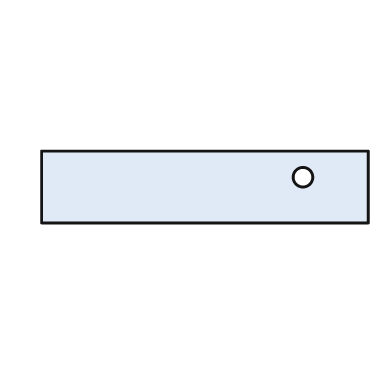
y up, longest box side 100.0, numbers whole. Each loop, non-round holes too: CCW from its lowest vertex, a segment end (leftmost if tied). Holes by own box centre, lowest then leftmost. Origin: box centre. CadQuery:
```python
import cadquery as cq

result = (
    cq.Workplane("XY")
    .moveTo(-50.0, -11.0)
    .lineTo(50.0, -11.0)
    .lineTo(50.0, 11.0)
    .lineTo(-50.0, 11.0)
    .close()
    .moveTo(30.0, 3.0)
    .circle(3.0)
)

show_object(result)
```